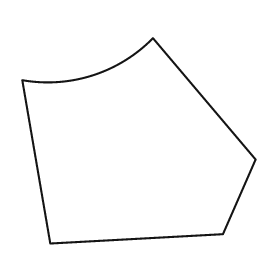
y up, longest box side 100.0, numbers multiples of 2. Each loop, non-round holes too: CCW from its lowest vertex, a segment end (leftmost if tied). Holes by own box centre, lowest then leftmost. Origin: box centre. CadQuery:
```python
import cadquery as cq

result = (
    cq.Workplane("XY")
    .moveTo(-38.0, -44.0)
    .lineTo(36.0, -40.0)
    .lineTo(50.0, -8.0)
    .lineTo(6.0, 44.0)
    .threePointArc((-20.0, 28.0), (-50.0, 26.0))
    .close()
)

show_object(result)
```